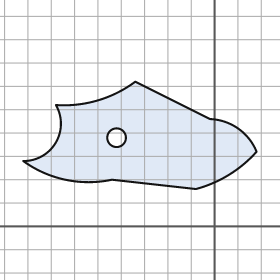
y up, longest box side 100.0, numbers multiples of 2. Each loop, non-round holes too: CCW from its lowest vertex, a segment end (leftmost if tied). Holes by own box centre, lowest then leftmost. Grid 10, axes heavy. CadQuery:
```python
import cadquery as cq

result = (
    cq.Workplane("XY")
    .moveTo(-8.0, 16.0)
    .threePointArc((6.0, 22.0), (18.0, 32.0))
    .threePointArc((10.0, 42.0), (-2.0, 46.0))
    .lineTo(-34.0, 62.0)
    .threePointArc((-50.0, 54.0), (-68.0, 52.0))
    .threePointArc((-68.0, 36.0), (-82.0, 28.0))
    .threePointArc((-64.0, 20.0), (-44.0, 20.0))
    .close()
    .moveTo(-42.0, 38.0)
    .circle(4.0)
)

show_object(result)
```